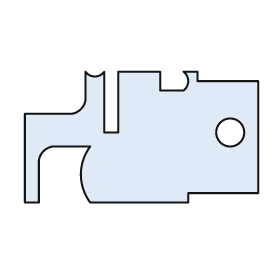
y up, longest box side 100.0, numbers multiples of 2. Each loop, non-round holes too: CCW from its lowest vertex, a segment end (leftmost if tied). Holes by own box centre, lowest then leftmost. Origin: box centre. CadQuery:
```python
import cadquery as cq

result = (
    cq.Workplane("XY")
    .moveTo(-50.0, -28.0)
    .lineTo(-44.0, -28.0)
    .lineTo(-44.0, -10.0)
    .threePointArc((-42.0, -6.0), (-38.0, -4.0))
    .lineTo(-22.0, -4.0)
    .threePointArc((-26.0, -16.0), (-22.0, -28.0))
    .lineTo(20.0, -28.0)
    .lineTo(20.0, -24.0)
    .lineTo(50.0, -24.0)
    .lineTo(50.0, 24.0)
    .lineTo(24.0, 24.0)
    .lineTo(24.0, 28.0)
    .lineTo(18.0, 28.0)
    .threePointArc((20.0, 24.0), (18.0, 20.0))
    .lineTo(8.0, 20.0)
    .lineTo(8.0, 28.0)
    .lineTo(-10.0, 28.0)
    .lineTo(-10.0, 2.0)
    .lineTo(-16.0, 2.0)
    .lineTo(-16.0, 28.0)
    .threePointArc((-20.0, 26.0), (-24.0, 28.0))
    .lineTo(-24.0, 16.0)
    .threePointArc((-26.0, 12.0), (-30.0, 10.0))
    .lineTo(-50.0, 10.0)
    .close()
    .moveTo(38.0, 2.0)
    .circle(6.0)
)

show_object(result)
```